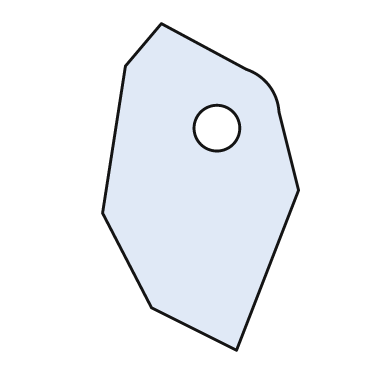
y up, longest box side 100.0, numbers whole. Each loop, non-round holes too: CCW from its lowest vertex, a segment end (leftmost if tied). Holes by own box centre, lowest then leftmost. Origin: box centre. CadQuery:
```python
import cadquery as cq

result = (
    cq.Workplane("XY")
    .moveTo(11.0, -50.0)
    .lineTo(30.0, -1.0)
    .lineTo(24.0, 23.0)
    .threePointArc((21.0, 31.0), (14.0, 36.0))
    .lineTo(-12.0, 50.0)
    .lineTo(-23.0, 37.0)
    .lineTo(-30.0, -8.0)
    .lineTo(-15.0, -37.0)
    .close()
    .moveTo(5.0, 18.0)
    .circle(7.0)
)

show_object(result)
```